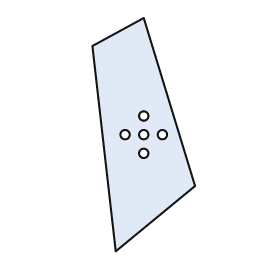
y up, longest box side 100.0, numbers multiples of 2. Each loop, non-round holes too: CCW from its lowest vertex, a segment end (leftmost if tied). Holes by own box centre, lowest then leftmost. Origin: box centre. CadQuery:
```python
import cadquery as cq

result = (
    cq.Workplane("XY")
    .moveTo(-12.0, -50.0)
    .lineTo(22.0, -22.0)
    .lineTo(0.0, 50.0)
    .lineTo(-22.0, 38.0)
    .close()
    .moveTo(0.0, -8.0)
    .circle(2.0)
    .moveTo(-8.0, 0.0)
    .circle(2.0)
    .moveTo(0.0, 0.0)
    .circle(2.0)
    .moveTo(8.0, 0.0)
    .circle(2.0)
    .moveTo(0.0, 8.0)
    .circle(2.0)
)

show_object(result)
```